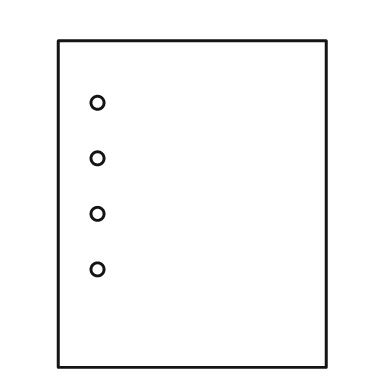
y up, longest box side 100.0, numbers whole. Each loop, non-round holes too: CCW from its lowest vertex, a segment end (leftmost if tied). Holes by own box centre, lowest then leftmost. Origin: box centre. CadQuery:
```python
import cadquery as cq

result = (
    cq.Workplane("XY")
    .moveTo(-41.0, -50.0)
    .lineTo(41.0, -50.0)
    .lineTo(41.0, 50.0)
    .lineTo(-41.0, 50.0)
    .close()
    .moveTo(-29.0, -20.0)
    .circle(2.0)
    .moveTo(-29.0, -3.0)
    .circle(2.0)
    .moveTo(-29.0, 14.0)
    .circle(2.0)
    .moveTo(-29.0, 31.0)
    .circle(2.0)
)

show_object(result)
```